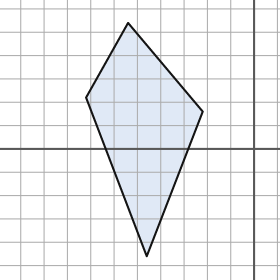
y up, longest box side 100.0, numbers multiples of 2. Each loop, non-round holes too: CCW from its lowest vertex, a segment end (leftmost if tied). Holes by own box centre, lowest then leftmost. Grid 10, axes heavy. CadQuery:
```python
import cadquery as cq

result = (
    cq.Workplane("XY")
    .moveTo(-46.0, -46.0)
    .lineTo(-22.0, 16.0)
    .lineTo(-54.0, 54.0)
    .lineTo(-72.0, 22.0)
    .close()
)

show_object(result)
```